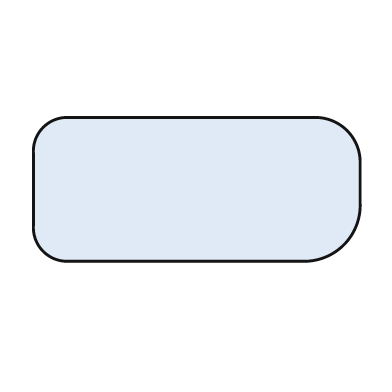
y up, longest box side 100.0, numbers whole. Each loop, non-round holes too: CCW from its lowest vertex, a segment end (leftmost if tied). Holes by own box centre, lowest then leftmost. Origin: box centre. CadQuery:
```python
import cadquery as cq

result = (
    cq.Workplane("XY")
    .moveTo(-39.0, -22.0)
    .lineTo(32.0, -22.0)
    .threePointArc((45.0, -17.0), (50.0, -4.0))
    .lineTo(50.0, 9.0)
    .threePointArc((46.0, 18.0), (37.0, 22.0))
    .lineTo(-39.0, 22.0)
    .threePointArc((-47.0, 19.0), (-50.0, 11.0))
    .lineTo(-50.0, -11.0)
    .threePointArc((-47.0, -19.0), (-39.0, -22.0))
    .close()
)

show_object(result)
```